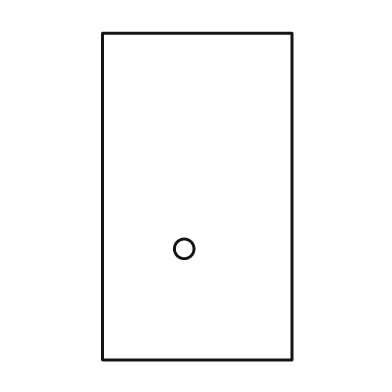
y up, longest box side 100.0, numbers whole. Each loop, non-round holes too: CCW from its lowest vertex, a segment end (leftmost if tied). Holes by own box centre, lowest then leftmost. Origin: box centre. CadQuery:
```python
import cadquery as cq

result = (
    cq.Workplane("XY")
    .moveTo(-29.0, -50.0)
    .lineTo(29.0, -50.0)
    .lineTo(29.0, 50.0)
    .lineTo(-29.0, 50.0)
    .close()
    .moveTo(-4.0, -16.0)
    .circle(3.0)
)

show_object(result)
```